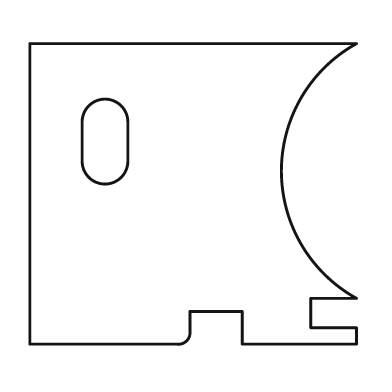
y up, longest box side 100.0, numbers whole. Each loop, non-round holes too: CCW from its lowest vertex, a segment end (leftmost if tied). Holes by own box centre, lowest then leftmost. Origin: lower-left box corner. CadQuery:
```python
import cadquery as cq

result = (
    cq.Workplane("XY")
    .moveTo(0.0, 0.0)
    .lineTo(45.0, 0.0)
    .threePointArc((48.0, 1.0), (49.0, 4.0))
    .lineTo(49.0, 10.0)
    .lineTo(65.0, 10.0)
    .lineTo(65.0, 0.0)
    .lineTo(100.0, 0.0)
    .lineTo(100.0, 5.0)
    .lineTo(86.0, 5.0)
    .lineTo(86.0, 14.0)
    .lineTo(100.0, 14.0)
    .threePointArc((77.0, 53.0), (100.0, 92.0))
    .lineTo(0.0, 92.0)
    .close()
    .moveTo(16.0, 56.0)
    .threePointArc((23.0, 49.0), (30.0, 56.0))
    .lineTo(30.0, 68.0)
    .threePointArc((23.0, 75.0), (16.0, 68.0))
    .close()
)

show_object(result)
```